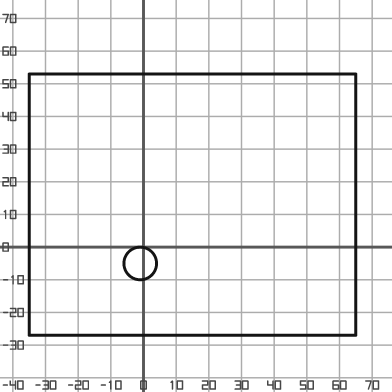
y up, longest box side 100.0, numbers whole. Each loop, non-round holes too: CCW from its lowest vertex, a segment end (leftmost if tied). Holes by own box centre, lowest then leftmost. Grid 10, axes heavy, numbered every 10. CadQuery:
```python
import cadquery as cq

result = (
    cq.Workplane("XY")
    .moveTo(-35.0, -27.0)
    .lineTo(65.0, -27.0)
    .lineTo(65.0, 53.0)
    .lineTo(-35.0, 53.0)
    .close()
    .moveTo(-1.0, -5.0)
    .circle(5.0)
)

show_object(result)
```